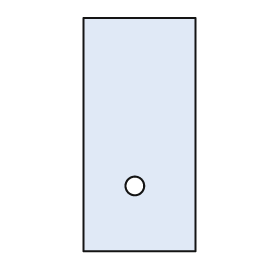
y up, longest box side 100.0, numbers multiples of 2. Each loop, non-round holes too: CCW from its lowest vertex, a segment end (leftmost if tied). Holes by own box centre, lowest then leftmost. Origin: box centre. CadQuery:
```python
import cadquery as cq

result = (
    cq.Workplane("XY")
    .moveTo(-24.0, -50.0)
    .lineTo(24.0, -50.0)
    .lineTo(24.0, 50.0)
    .lineTo(-24.0, 50.0)
    .close()
    .moveTo(-2.0, -22.0)
    .circle(4.0)
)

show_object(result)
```